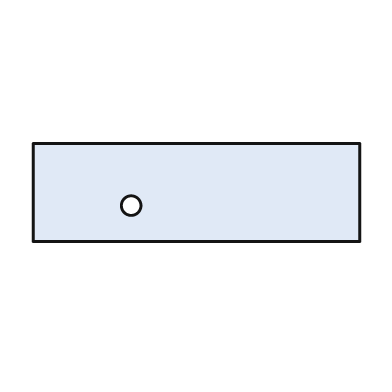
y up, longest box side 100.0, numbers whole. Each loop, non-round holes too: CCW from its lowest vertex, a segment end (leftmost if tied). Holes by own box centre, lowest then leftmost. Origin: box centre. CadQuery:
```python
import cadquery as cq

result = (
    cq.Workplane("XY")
    .moveTo(-50.0, -15.0)
    .lineTo(50.0, -15.0)
    .lineTo(50.0, 15.0)
    .lineTo(-50.0, 15.0)
    .close()
    .moveTo(-20.0, -4.0)
    .circle(3.0)
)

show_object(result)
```